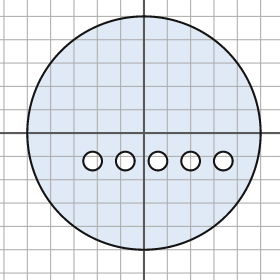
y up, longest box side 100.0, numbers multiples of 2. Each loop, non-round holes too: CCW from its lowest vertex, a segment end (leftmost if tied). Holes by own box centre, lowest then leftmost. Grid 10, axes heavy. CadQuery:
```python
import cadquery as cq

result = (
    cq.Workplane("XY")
    .moveTo(0.0, 0.0)
    .circle(50.0)
    .moveTo(-22.0, -12.0)
    .circle(4.0)
    .moveTo(-8.0, -12.0)
    .circle(4.0)
    .moveTo(6.0, -12.0)
    .circle(4.0)
    .moveTo(20.0, -12.0)
    .circle(4.0)
    .moveTo(34.0, -12.0)
    .circle(4.0)
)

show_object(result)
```